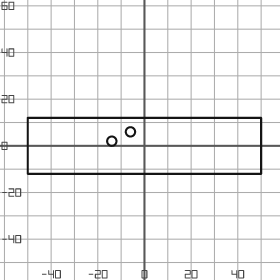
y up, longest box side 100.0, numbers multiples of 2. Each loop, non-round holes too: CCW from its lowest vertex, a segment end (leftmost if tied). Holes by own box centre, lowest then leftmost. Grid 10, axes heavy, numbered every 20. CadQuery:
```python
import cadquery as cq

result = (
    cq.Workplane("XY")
    .moveTo(-50.0, -12.0)
    .lineTo(50.0, -12.0)
    .lineTo(50.0, 12.0)
    .lineTo(-50.0, 12.0)
    .close()
    .moveTo(-14.0, 2.0)
    .circle(2.0)
    .moveTo(-6.0, 6.0)
    .circle(2.0)
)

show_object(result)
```